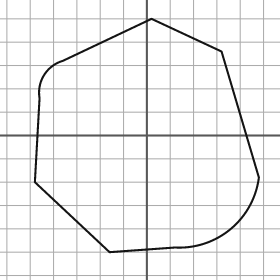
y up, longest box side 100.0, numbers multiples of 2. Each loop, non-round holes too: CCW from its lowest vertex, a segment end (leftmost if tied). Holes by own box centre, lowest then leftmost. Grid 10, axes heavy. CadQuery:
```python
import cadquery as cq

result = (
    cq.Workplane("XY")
    .moveTo(-16.0, -50.0)
    .lineTo(12.0, -48.0)
    .threePointArc((36.0, -40.0), (48.0, -18.0))
    .lineTo(32.0, 36.0)
    .lineTo(2.0, 50.0)
    .lineTo(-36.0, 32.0)
    .threePointArc((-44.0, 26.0), (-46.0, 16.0))
    .lineTo(-48.0, -20.0)
    .close()
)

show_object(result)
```